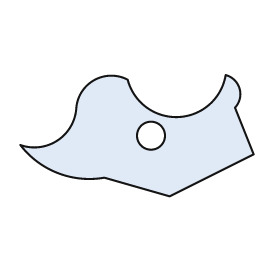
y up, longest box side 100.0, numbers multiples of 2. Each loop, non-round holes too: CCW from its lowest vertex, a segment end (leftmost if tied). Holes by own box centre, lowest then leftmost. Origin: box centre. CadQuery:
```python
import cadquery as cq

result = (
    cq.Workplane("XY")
    .moveTo(14.0, -26.0)
    .lineTo(50.0, -8.0)
    .lineTo(42.0, 12.0)
    .threePointArc((44.0, 20.0), (38.0, 26.0))
    .threePointArc((18.0, 8.0), (-4.0, 24.0))
    .threePointArc((-18.0, 24.0), (-26.0, 12.0))
    .threePointArc((-34.0, -2.0), (-50.0, -4.0))
    .threePointArc((-34.0, -16.0), (-14.0, -18.0))
    .close()
    .moveTo(6.0, 0.0)
    .circle(6.0)
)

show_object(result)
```